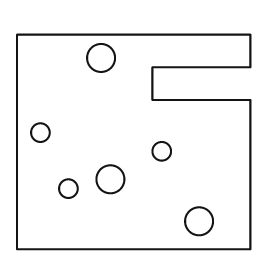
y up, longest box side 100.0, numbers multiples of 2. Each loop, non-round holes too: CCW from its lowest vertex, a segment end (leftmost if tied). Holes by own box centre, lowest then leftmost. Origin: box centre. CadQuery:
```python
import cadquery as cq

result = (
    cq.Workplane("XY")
    .moveTo(-50.0, -46.0)
    .lineTo(50.0, -46.0)
    .lineTo(50.0, 18.0)
    .lineTo(8.0, 18.0)
    .lineTo(8.0, 32.0)
    .lineTo(50.0, 32.0)
    .lineTo(50.0, 46.0)
    .lineTo(-50.0, 46.0)
    .close()
    .moveTo(28.0, -34.0)
    .circle(6.0)
    .moveTo(-28.0, -20.0)
    .circle(4.0)
    .moveTo(-10.0, -16.0)
    .circle(6.0)
    .moveTo(12.0, -4.0)
    .circle(4.0)
    .moveTo(-40.0, 4.0)
    .circle(4.0)
    .moveTo(-14.0, 36.0)
    .circle(6.0)
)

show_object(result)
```